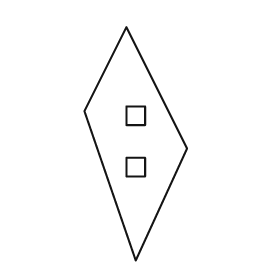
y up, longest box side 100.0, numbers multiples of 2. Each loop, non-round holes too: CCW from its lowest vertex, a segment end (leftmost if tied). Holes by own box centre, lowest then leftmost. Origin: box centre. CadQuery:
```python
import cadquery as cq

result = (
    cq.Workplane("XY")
    .moveTo(0.0, -50.0)
    .lineTo(22.0, -2.0)
    .lineTo(-4.0, 50.0)
    .lineTo(-22.0, 14.0)
    .close()
    .moveTo(-4.0, -14.0)
    .lineTo(4.0, -14.0)
    .lineTo(4.0, -6.0)
    .lineTo(-4.0, -6.0)
    .close()
    .moveTo(-4.0, 8.0)
    .lineTo(4.0, 8.0)
    .lineTo(4.0, 16.0)
    .lineTo(-4.0, 16.0)
    .close()
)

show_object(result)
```